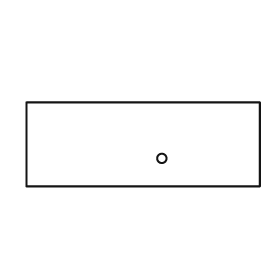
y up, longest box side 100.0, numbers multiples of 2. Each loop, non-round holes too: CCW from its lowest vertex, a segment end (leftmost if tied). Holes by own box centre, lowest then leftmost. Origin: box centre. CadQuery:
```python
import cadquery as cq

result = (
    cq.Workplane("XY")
    .moveTo(-50.0, -18.0)
    .lineTo(50.0, -18.0)
    .lineTo(50.0, 18.0)
    .lineTo(-50.0, 18.0)
    .close()
    .moveTo(8.0, -6.0)
    .circle(2.0)
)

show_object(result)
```